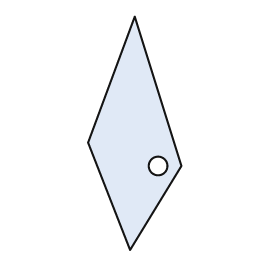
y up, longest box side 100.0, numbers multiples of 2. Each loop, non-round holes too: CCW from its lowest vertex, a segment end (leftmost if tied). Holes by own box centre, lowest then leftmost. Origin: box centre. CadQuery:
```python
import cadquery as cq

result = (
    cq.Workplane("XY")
    .moveTo(-2.0, -50.0)
    .lineTo(20.0, -14.0)
    .lineTo(0.0, 50.0)
    .lineTo(-20.0, -4.0)
    .close()
    .moveTo(10.0, -14.0)
    .circle(4.0)
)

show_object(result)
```